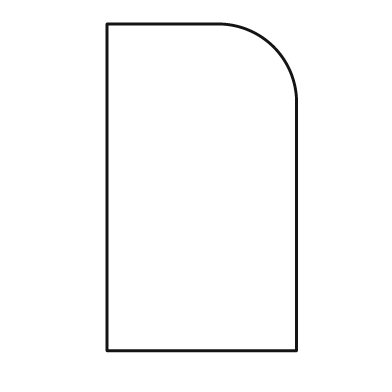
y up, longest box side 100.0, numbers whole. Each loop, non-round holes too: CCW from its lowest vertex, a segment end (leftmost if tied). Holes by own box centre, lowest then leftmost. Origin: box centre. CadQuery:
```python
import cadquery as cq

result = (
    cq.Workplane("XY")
    .moveTo(-29.0, -50.0)
    .lineTo(29.0, -50.0)
    .lineTo(29.0, 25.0)
    .threePointArc((22.0, 43.0), (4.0, 50.0))
    .lineTo(-29.0, 50.0)
    .close()
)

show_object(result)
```